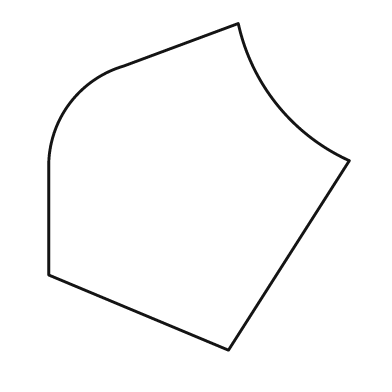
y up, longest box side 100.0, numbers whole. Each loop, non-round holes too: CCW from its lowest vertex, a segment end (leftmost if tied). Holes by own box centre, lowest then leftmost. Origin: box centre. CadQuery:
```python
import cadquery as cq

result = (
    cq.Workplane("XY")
    .moveTo(9.0, -50.0)
    .lineTo(46.0, 8.0)
    .threePointArc((24.0, 25.0), (12.0, 50.0))
    .lineTo(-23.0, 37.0)
    .threePointArc((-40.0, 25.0), (-46.0, 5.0))
    .lineTo(-46.0, -27.0)
    .close()
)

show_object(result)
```